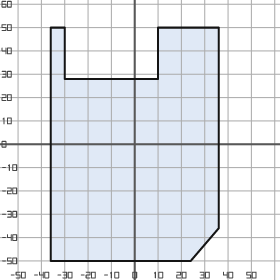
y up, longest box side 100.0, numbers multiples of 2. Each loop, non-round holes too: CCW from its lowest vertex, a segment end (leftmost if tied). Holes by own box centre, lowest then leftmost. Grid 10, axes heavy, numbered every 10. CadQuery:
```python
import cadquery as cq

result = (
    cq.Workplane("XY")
    .moveTo(-36.0, -50.0)
    .lineTo(24.0, -50.0)
    .lineTo(36.0, -36.0)
    .lineTo(36.0, 50.0)
    .lineTo(10.0, 50.0)
    .lineTo(10.0, 28.0)
    .lineTo(-30.0, 28.0)
    .lineTo(-30.0, 50.0)
    .lineTo(-36.0, 50.0)
    .close()
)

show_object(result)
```